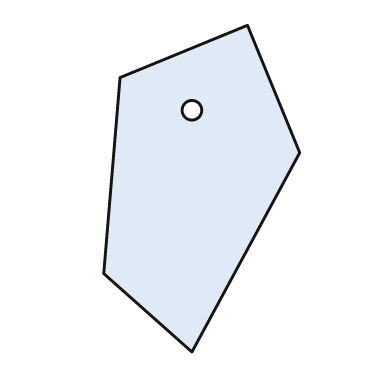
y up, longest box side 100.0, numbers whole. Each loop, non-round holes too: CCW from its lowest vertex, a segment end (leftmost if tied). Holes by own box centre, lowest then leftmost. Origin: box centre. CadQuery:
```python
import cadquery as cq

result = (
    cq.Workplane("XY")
    .moveTo(-3.0, -50.0)
    .lineTo(30.0, 11.0)
    .lineTo(14.0, 50.0)
    .lineTo(-25.0, 34.0)
    .lineTo(-30.0, -26.0)
    .close()
    .moveTo(-3.0, 24.0)
    .circle(3.0)
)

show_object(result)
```